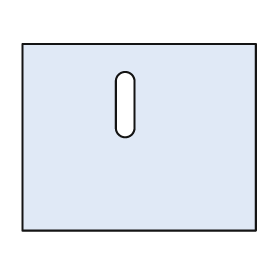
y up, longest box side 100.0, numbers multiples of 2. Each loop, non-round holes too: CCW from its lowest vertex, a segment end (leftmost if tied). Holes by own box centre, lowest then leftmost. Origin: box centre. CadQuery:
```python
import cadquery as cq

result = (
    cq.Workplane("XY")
    .moveTo(-50.0, -40.0)
    .lineTo(50.0, -40.0)
    .lineTo(50.0, 40.0)
    .lineTo(-50.0, 40.0)
    .close()
    .moveTo(-10.0, 4.0)
    .threePointArc((-6.0, 0.0), (-2.0, 4.0))
    .lineTo(-2.0, 24.0)
    .threePointArc((-6.0, 28.0), (-10.0, 24.0))
    .close()
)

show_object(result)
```